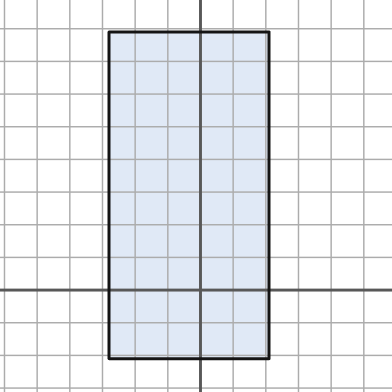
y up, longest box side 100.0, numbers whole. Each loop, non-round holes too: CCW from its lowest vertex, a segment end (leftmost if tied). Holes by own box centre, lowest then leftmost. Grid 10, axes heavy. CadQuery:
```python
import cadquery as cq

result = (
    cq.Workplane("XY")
    .moveTo(-28.0, -21.0)
    .lineTo(21.0, -21.0)
    .lineTo(21.0, 79.0)
    .lineTo(-28.0, 79.0)
    .close()
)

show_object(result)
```